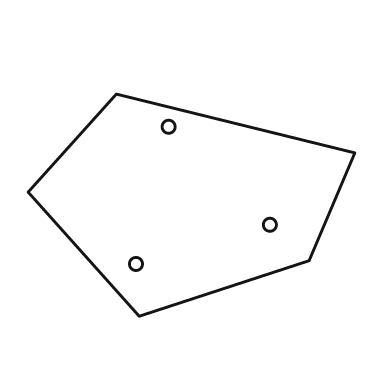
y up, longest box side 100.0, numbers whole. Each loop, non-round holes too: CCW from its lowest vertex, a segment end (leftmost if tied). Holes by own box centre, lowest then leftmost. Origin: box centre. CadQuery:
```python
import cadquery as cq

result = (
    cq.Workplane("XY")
    .moveTo(-16.0, -34.0)
    .lineTo(36.0, -17.0)
    .lineTo(50.0, 16.0)
    .lineTo(-23.0, 34.0)
    .lineTo(-50.0, 4.0)
    .close()
    .moveTo(-17.0, -18.0)
    .circle(2.0)
    .moveTo(24.0, -6.0)
    .circle(2.0)
    .moveTo(-7.0, 24.0)
    .circle(2.0)
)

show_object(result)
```